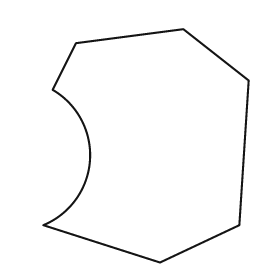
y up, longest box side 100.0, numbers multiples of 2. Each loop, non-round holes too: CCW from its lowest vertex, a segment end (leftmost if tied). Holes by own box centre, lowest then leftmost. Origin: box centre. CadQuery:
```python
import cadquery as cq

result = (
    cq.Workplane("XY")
    .moveTo(6.0, -50.0)
    .lineTo(40.0, -34.0)
    .lineTo(44.0, 28.0)
    .lineTo(16.0, 50.0)
    .lineTo(-30.0, 44.0)
    .lineTo(-40.0, 24.0)
    .threePointArc((-24.0, -6.0), (-44.0, -34.0))
    .close()
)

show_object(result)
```